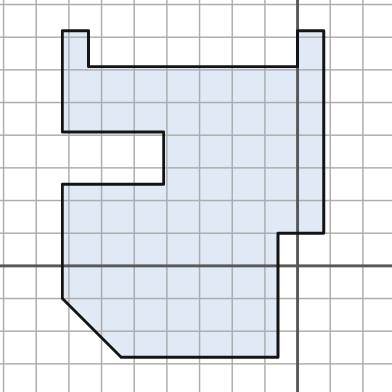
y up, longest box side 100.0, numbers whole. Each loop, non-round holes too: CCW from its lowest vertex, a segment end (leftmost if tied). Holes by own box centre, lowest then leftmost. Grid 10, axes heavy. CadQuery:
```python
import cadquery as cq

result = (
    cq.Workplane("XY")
    .moveTo(-54.0, -28.0)
    .lineTo(-6.0, -28.0)
    .lineTo(-6.0, 10.0)
    .lineTo(8.0, 10.0)
    .lineTo(8.0, 72.0)
    .lineTo(0.0, 72.0)
    .lineTo(0.0, 61.0)
    .lineTo(-64.0, 61.0)
    .lineTo(-64.0, 72.0)
    .lineTo(-72.0, 72.0)
    .lineTo(-72.0, 41.0)
    .lineTo(-41.0, 41.0)
    .lineTo(-41.0, 25.0)
    .lineTo(-72.0, 25.0)
    .lineTo(-72.0, -10.0)
    .close()
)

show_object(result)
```